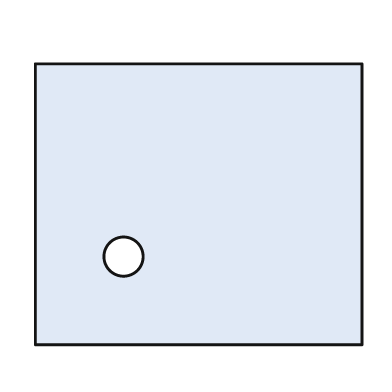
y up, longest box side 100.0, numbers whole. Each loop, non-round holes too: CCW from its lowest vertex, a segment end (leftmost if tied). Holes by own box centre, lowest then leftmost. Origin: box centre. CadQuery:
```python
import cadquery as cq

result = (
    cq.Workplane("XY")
    .moveTo(-50.0, -43.0)
    .lineTo(50.0, -43.0)
    .lineTo(50.0, 43.0)
    .lineTo(-50.0, 43.0)
    .close()
    .moveTo(-23.0, -16.0)
    .circle(6.0)
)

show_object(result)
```